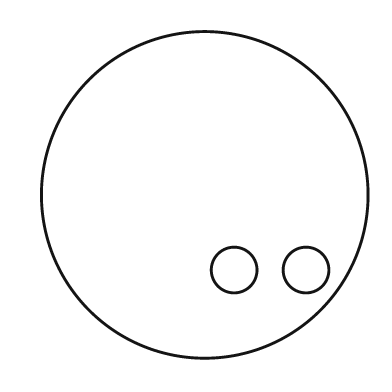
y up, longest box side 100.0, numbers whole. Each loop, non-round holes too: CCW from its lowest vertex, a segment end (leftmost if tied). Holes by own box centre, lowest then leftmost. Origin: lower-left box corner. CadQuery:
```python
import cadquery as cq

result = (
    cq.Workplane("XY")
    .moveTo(50.0, 50.0)
    .circle(50.0)
    .moveTo(59.0, 27.0)
    .circle(7.0)
    .moveTo(81.0, 27.0)
    .circle(7.0)
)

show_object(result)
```